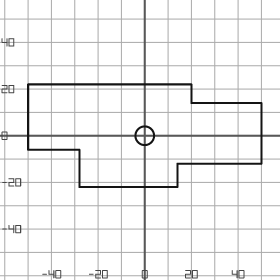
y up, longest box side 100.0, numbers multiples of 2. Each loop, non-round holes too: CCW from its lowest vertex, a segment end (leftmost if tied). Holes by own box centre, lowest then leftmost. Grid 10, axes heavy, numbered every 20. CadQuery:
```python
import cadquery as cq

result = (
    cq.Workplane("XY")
    .moveTo(-28.0, -22.0)
    .lineTo(14.0, -22.0)
    .lineTo(14.0, -12.0)
    .lineTo(50.0, -12.0)
    .lineTo(50.0, 14.0)
    .lineTo(20.0, 14.0)
    .lineTo(20.0, 22.0)
    .lineTo(-50.0, 22.0)
    .lineTo(-50.0, -6.0)
    .lineTo(-28.0, -6.0)
    .close()
    .moveTo(0.0, 0.0)
    .circle(4.0)
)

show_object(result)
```